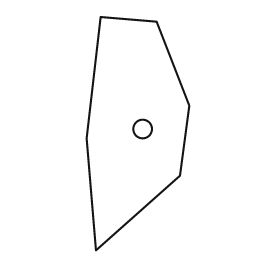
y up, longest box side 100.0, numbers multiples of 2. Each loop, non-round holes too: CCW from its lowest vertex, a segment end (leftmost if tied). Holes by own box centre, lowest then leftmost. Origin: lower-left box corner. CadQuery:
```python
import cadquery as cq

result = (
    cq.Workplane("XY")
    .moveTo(4.0, 0.0)
    .lineTo(40.0, 32.0)
    .lineTo(44.0, 62.0)
    .lineTo(30.0, 98.0)
    .lineTo(6.0, 100.0)
    .lineTo(0.0, 48.0)
    .close()
    .moveTo(24.0, 52.0)
    .circle(4.0)
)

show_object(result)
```